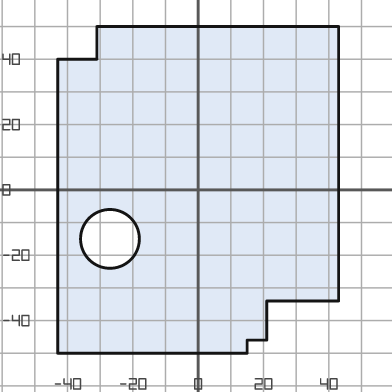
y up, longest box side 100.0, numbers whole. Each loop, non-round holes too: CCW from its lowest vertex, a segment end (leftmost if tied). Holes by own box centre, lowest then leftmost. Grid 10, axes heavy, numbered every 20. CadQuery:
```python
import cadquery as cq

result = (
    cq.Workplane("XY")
    .moveTo(-43.0, -50.0)
    .lineTo(15.0, -50.0)
    .lineTo(15.0, -46.0)
    .lineTo(21.0, -46.0)
    .lineTo(21.0, -34.0)
    .lineTo(43.0, -34.0)
    .lineTo(43.0, 50.0)
    .lineTo(-31.0, 50.0)
    .lineTo(-31.0, 40.0)
    .lineTo(-43.0, 40.0)
    .close()
    .moveTo(-27.0, -15.0)
    .circle(9.0)
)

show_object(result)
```